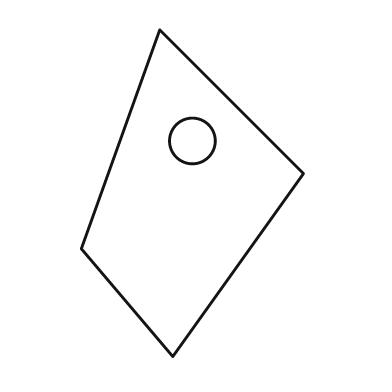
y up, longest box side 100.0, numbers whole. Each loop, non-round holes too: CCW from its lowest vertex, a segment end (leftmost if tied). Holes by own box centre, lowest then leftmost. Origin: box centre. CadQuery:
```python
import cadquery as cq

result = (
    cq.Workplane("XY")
    .moveTo(-6.0, -50.0)
    .lineTo(34.0, 6.0)
    .lineTo(-10.0, 50.0)
    .lineTo(-34.0, -17.0)
    .close()
    .moveTo(0.0, 16.0)
    .circle(7.0)
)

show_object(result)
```